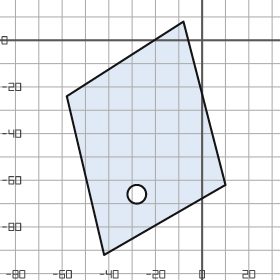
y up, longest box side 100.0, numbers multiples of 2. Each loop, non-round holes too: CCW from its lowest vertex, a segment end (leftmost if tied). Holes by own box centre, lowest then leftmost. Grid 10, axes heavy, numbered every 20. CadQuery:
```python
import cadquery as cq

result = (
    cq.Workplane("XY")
    .moveTo(-42.0, -92.0)
    .lineTo(10.0, -62.0)
    .lineTo(-8.0, 8.0)
    .lineTo(-58.0, -24.0)
    .close()
    .moveTo(-28.0, -66.0)
    .circle(4.0)
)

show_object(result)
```